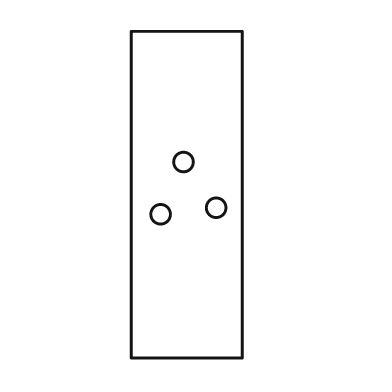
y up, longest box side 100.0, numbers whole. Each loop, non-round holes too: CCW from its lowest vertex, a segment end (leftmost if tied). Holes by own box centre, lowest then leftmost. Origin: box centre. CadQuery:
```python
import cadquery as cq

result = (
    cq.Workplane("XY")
    .moveTo(-17.0, -50.0)
    .lineTo(17.0, -50.0)
    .lineTo(17.0, 50.0)
    .lineTo(-17.0, 50.0)
    .close()
    .moveTo(-8.0, -6.0)
    .circle(3.0)
    .moveTo(9.0, -4.0)
    .circle(3.0)
    .moveTo(-1.0, 10.0)
    .circle(3.0)
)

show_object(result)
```